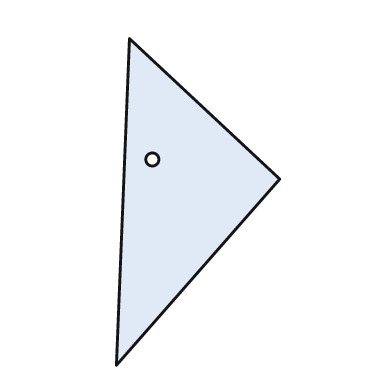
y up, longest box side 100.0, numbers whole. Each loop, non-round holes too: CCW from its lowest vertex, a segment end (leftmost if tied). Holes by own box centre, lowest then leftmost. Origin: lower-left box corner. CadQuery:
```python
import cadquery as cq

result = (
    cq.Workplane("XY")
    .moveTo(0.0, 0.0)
    .lineTo(50.0, 57.0)
    .lineTo(4.0, 100.0)
    .close()
    .moveTo(11.0, 63.0)
    .circle(2.0)
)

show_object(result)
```